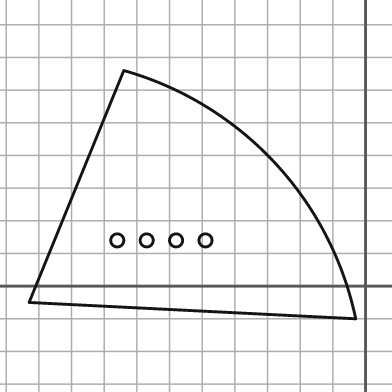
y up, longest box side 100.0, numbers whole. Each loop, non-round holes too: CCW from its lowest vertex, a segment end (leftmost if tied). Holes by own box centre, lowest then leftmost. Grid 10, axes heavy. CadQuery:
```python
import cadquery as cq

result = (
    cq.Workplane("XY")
    .moveTo(-3.0, -10.0)
    .threePointArc((-28.0, 38.0), (-74.0, 66.0))
    .lineTo(-103.0, -5.0)
    .close()
    .moveTo(-76.0, 14.0)
    .circle(2.0)
    .moveTo(-67.0, 14.0)
    .circle(2.0)
    .moveTo(-58.0, 14.0)
    .circle(2.0)
    .moveTo(-49.0, 14.0)
    .circle(2.0)
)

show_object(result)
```